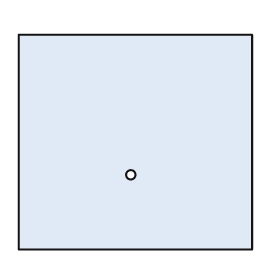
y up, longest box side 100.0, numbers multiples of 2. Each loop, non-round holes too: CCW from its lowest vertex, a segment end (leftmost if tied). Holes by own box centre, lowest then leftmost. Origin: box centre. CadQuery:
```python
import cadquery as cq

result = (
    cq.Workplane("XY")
    .moveTo(-50.0, -46.0)
    .lineTo(50.0, -46.0)
    .lineTo(50.0, 46.0)
    .lineTo(-50.0, 46.0)
    .close()
    .moveTo(-2.0, -14.0)
    .circle(2.0)
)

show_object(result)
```